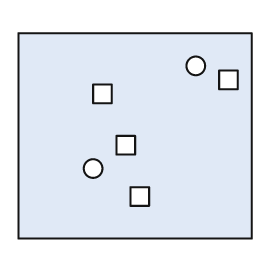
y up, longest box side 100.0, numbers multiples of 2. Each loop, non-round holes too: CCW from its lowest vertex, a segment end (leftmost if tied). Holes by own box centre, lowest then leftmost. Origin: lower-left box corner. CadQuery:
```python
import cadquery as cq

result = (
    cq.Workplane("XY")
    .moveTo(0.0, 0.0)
    .lineTo(100.0, 0.0)
    .lineTo(100.0, 88.0)
    .lineTo(0.0, 88.0)
    .close()
    .moveTo(48.0, 14.0)
    .lineTo(56.0, 14.0)
    .lineTo(56.0, 22.0)
    .lineTo(48.0, 22.0)
    .close()
    .moveTo(32.0, 30.0)
    .circle(4.0)
    .moveTo(42.0, 36.0)
    .lineTo(50.0, 36.0)
    .lineTo(50.0, 44.0)
    .lineTo(42.0, 44.0)
    .close()
    .moveTo(32.0, 58.0)
    .lineTo(40.0, 58.0)
    .lineTo(40.0, 66.0)
    .lineTo(32.0, 66.0)
    .close()
    .moveTo(86.0, 64.0)
    .lineTo(94.0, 64.0)
    .lineTo(94.0, 72.0)
    .lineTo(86.0, 72.0)
    .close()
    .moveTo(76.0, 74.0)
    .circle(4.0)
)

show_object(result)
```